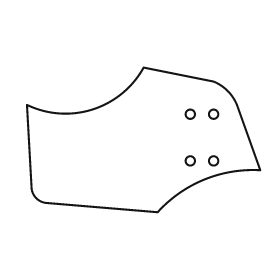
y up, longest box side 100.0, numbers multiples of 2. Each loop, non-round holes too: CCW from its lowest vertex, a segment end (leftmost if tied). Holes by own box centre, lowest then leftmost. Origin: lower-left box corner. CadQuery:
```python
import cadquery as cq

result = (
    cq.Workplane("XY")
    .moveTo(56.0, 0.0)
    .threePointArc((76.0, 14.0), (100.0, 18.0))
    .lineTo(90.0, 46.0)
    .threePointArc((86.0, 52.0), (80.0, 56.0))
    .lineTo(50.0, 62.0)
    .threePointArc((28.0, 44.0), (0.0, 46.0))
    .lineTo(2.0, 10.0)
    .threePointArc((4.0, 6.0), (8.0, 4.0))
    .close()
    .moveTo(70.0, 22.0)
    .circle(2.0)
    .moveTo(80.0, 22.0)
    .circle(2.0)
    .moveTo(70.0, 42.0)
    .circle(2.0)
    .moveTo(80.0, 42.0)
    .circle(2.0)
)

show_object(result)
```